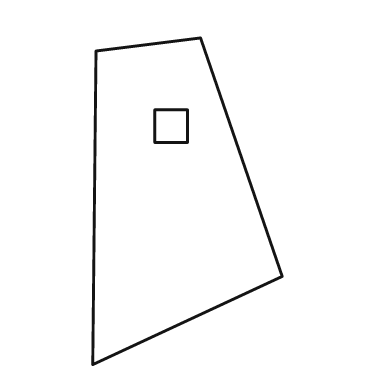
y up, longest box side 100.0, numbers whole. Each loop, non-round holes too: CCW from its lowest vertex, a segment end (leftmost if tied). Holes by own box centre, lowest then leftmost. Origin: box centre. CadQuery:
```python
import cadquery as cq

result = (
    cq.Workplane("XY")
    .moveTo(-29.0, -50.0)
    .lineTo(29.0, -23.0)
    .lineTo(4.0, 50.0)
    .lineTo(-28.0, 46.0)
    .close()
    .moveTo(-10.0, 18.0)
    .lineTo(0.0, 18.0)
    .lineTo(0.0, 28.0)
    .lineTo(-10.0, 28.0)
    .close()
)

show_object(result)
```